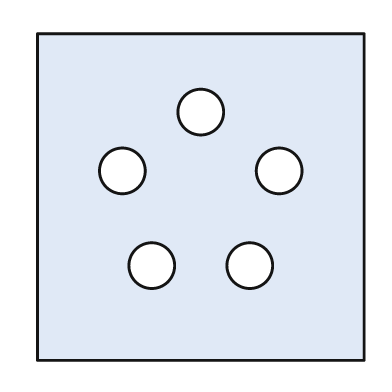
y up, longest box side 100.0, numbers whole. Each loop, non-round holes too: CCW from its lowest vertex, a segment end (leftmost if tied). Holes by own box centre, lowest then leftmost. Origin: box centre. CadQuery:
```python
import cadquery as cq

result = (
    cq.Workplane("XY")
    .moveTo(-50.0, -50.0)
    .lineTo(50.0, -50.0)
    .lineTo(50.0, 50.0)
    .lineTo(-50.0, 50.0)
    .close()
    .moveTo(-15.0, -21.0)
    .circle(7.0)
    .moveTo(15.0, -21.0)
    .circle(7.0)
    .moveTo(-24.0, 8.0)
    .circle(7.0)
    .moveTo(24.0, 8.0)
    .circle(7.0)
    .moveTo(0.0, 26.0)
    .circle(7.0)
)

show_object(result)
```